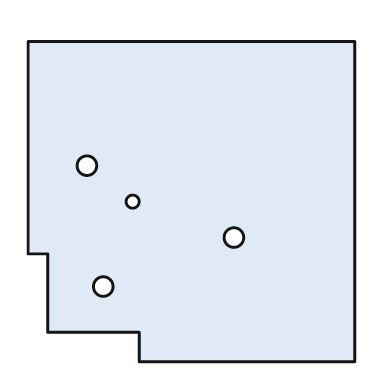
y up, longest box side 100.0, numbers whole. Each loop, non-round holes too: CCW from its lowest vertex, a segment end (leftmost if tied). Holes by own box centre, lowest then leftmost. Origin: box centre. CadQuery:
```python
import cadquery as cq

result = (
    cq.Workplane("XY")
    .moveTo(-16.0, -49.0)
    .lineTo(50.0, -49.0)
    .lineTo(50.0, 49.0)
    .lineTo(-50.0, 49.0)
    .lineTo(-50.0, -16.0)
    .lineTo(-44.0, -16.0)
    .lineTo(-44.0, -40.0)
    .lineTo(-16.0, -40.0)
    .close()
    .moveTo(-27.0, -26.0)
    .circle(3.0)
    .moveTo(13.0, -11.0)
    .circle(3.0)
    .moveTo(-18.0, 0.0)
    .circle(2.0)
    .moveTo(-32.0, 11.0)
    .circle(3.0)
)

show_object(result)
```